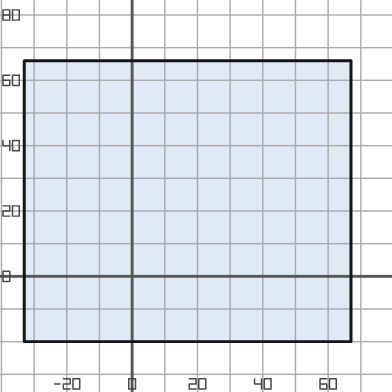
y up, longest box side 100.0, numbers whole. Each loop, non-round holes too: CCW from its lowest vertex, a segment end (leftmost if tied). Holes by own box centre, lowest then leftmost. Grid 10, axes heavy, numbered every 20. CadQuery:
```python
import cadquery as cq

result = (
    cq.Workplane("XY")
    .moveTo(-33.0, -20.0)
    .lineTo(67.0, -20.0)
    .lineTo(67.0, 66.0)
    .lineTo(-33.0, 66.0)
    .close()
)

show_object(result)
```